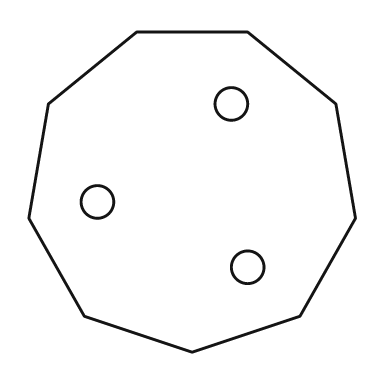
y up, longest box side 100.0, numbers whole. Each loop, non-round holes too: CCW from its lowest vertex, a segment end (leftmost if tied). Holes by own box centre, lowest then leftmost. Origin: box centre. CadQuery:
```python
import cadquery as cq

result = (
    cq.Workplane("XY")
    .moveTo(0.0, -49.0)
    .lineTo(33.0, -38.0)
    .lineTo(50.0, -8.0)
    .lineTo(44.0, 27.0)
    .lineTo(17.0, 49.0)
    .lineTo(-17.0, 49.0)
    .lineTo(-44.0, 27.0)
    .lineTo(-50.0, -8.0)
    .lineTo(-33.0, -38.0)
    .close()
    .moveTo(17.0, -23.0)
    .circle(5.0)
    .moveTo(-29.0, -3.0)
    .circle(5.0)
    .moveTo(12.0, 27.0)
    .circle(5.0)
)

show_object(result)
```